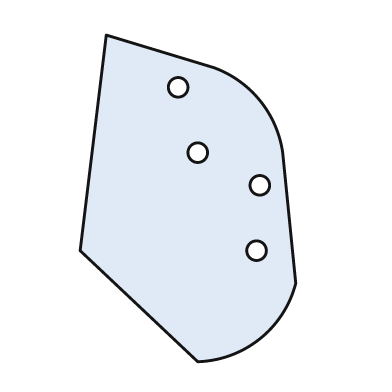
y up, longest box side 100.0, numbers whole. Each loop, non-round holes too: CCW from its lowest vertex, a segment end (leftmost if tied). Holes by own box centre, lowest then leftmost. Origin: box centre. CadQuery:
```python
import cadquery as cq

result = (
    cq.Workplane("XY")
    .moveTo(3.0, -50.0)
    .threePointArc((22.0, -43.0), (33.0, -26.0))
    .lineTo(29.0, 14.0)
    .threePointArc((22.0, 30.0), (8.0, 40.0))
    .lineTo(-25.0, 50.0)
    .lineTo(-33.0, -16.0)
    .close()
    .moveTo(21.0, -16.0)
    .circle(3.0)
    .moveTo(22.0, 4.0)
    .circle(3.0)
    .moveTo(3.0, 14.0)
    .circle(3.0)
    .moveTo(-3.0, 34.0)
    .circle(3.0)
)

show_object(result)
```